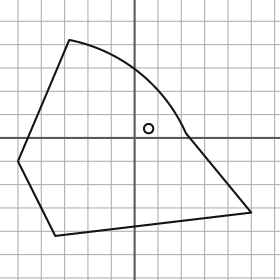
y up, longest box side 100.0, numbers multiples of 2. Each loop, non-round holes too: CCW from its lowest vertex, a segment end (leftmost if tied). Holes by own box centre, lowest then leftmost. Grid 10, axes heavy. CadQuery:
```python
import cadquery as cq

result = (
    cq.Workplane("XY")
    .moveTo(-34.0, -42.0)
    .lineTo(50.0, -32.0)
    .lineTo(22.0, 2.0)
    .threePointArc((2.0, 28.0), (-28.0, 42.0))
    .lineTo(-50.0, -10.0)
    .close()
    .moveTo(6.0, 4.0)
    .circle(2.0)
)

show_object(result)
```